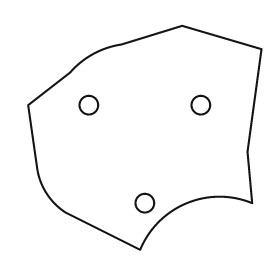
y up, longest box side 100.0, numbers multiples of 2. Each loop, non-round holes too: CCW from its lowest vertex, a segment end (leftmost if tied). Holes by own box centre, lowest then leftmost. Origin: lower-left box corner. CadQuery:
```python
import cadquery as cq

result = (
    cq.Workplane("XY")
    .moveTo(48.0, 0.0)
    .threePointArc((68.0, 20.0), (96.0, 20.0))
    .lineTo(94.0, 42.0)
    .lineTo(100.0, 86.0)
    .lineTo(66.0, 96.0)
    .lineTo(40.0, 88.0)
    .threePointArc((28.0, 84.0), (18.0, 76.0))
    .lineTo(0.0, 62.0)
    .lineTo(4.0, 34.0)
    .threePointArc((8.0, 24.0), (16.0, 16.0))
    .close()
    .moveTo(50.0, 20.0)
    .circle(4.0)
    .moveTo(26.0, 62.0)
    .circle(4.0)
    .moveTo(74.0, 62.0)
    .circle(4.0)
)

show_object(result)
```